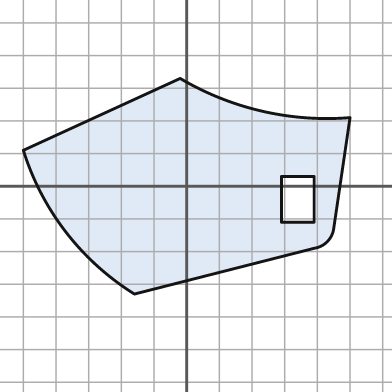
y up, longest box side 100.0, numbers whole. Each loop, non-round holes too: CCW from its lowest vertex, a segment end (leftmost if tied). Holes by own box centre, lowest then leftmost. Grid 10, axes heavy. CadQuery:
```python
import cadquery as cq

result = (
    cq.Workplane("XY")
    .moveTo(-16.0, -33.0)
    .lineTo(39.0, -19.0)
    .threePointArc((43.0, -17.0), (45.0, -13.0))
    .lineTo(50.0, 21.0)
    .threePointArc((23.0, 23.0), (-2.0, 33.0))
    .lineTo(-50.0, 11.0)
    .threePointArc((-37.0, -14.0), (-16.0, -33.0))
    .close()
    .moveTo(29.0, -11.0)
    .lineTo(39.0, -11.0)
    .lineTo(39.0, 3.0)
    .lineTo(29.0, 3.0)
    .close()
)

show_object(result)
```